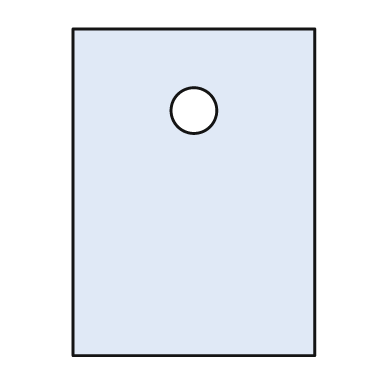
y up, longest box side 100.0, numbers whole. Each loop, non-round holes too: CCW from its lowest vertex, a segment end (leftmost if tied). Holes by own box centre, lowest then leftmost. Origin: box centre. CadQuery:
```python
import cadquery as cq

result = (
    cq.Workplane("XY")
    .moveTo(-37.0, -50.0)
    .lineTo(37.0, -50.0)
    .lineTo(37.0, 50.0)
    .lineTo(-37.0, 50.0)
    .close()
    .moveTo(0.0, 25.0)
    .circle(7.0)
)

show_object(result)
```